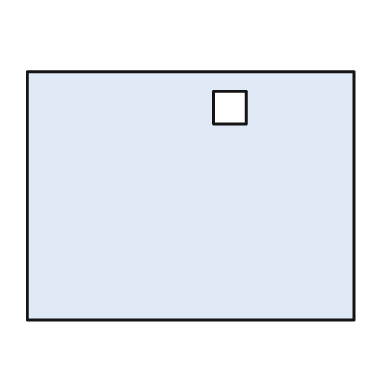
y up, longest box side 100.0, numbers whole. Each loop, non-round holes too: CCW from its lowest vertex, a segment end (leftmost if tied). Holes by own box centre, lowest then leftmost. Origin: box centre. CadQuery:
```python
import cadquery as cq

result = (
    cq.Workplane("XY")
    .moveTo(-50.0, -38.0)
    .lineTo(50.0, -38.0)
    .lineTo(50.0, 38.0)
    .lineTo(-50.0, 38.0)
    .close()
    .moveTo(7.0, 22.0)
    .lineTo(17.0, 22.0)
    .lineTo(17.0, 32.0)
    .lineTo(7.0, 32.0)
    .close()
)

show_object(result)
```